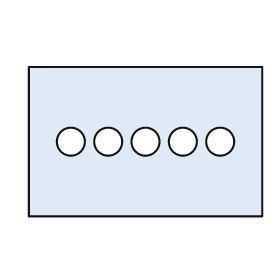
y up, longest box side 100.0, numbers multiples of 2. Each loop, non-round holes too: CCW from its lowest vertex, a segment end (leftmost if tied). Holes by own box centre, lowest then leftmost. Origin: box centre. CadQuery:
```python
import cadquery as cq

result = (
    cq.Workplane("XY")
    .moveTo(-50.0, -32.0)
    .lineTo(50.0, -32.0)
    .lineTo(50.0, 32.0)
    .lineTo(-50.0, 32.0)
    .close()
    .moveTo(-32.0, 0.0)
    .circle(6.0)
    .moveTo(-16.0, 0.0)
    .circle(6.0)
    .moveTo(0.0, 0.0)
    .circle(6.0)
    .moveTo(16.0, 0.0)
    .circle(6.0)
    .moveTo(32.0, 0.0)
    .circle(6.0)
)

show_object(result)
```